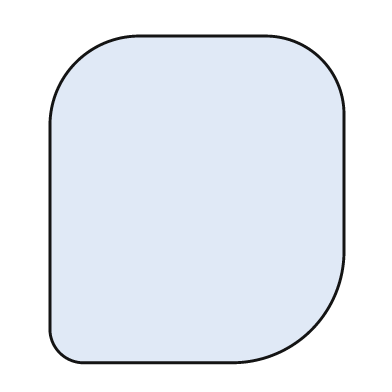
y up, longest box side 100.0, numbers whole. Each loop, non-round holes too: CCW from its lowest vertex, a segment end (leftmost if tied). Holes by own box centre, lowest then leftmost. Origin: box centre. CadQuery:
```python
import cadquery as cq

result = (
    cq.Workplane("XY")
    .moveTo(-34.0, -50.0)
    .lineTo(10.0, -50.0)
    .threePointArc((35.0, -40.0), (45.0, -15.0))
    .lineTo(45.0, 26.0)
    .threePointArc((38.0, 43.0), (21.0, 50.0))
    .lineTo(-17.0, 50.0)
    .threePointArc((-37.0, 42.0), (-45.0, 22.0))
    .lineTo(-45.0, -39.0)
    .threePointArc((-42.0, -47.0), (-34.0, -50.0))
    .close()
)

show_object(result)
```